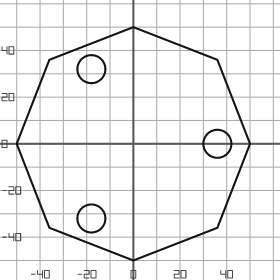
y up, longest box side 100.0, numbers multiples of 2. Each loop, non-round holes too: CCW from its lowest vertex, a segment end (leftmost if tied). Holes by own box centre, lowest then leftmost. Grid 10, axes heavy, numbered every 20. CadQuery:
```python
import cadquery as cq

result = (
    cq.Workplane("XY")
    .moveTo(0.0, -50.0)
    .lineTo(36.0, -36.0)
    .lineTo(50.0, 0.0)
    .lineTo(36.0, 36.0)
    .lineTo(0.0, 50.0)
    .lineTo(-36.0, 36.0)
    .lineTo(-50.0, 0.0)
    .lineTo(-36.0, -36.0)
    .close()
    .moveTo(-18.0, -32.0)
    .circle(6.0)
    .moveTo(36.0, 0.0)
    .circle(6.0)
    .moveTo(-18.0, 32.0)
    .circle(6.0)
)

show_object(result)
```